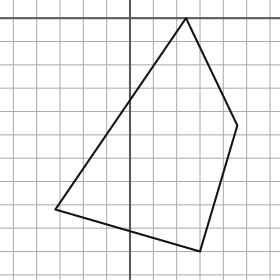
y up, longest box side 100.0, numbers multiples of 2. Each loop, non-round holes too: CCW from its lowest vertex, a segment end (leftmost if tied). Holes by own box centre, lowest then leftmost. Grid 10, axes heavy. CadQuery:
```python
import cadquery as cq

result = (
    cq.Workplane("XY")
    .moveTo(30.0, -100.0)
    .lineTo(46.0, -46.0)
    .lineTo(24.0, 0.0)
    .lineTo(-32.0, -82.0)
    .close()
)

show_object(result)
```